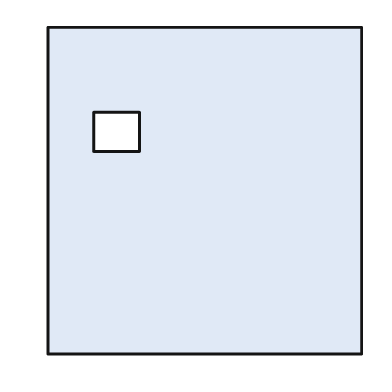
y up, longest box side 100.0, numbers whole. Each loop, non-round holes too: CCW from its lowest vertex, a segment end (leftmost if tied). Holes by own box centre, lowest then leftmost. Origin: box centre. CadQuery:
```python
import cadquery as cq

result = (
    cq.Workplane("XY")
    .moveTo(-48.0, -50.0)
    .lineTo(48.0, -50.0)
    .lineTo(48.0, 50.0)
    .lineTo(-48.0, 50.0)
    .close()
    .moveTo(-34.0, 12.0)
    .lineTo(-20.0, 12.0)
    .lineTo(-20.0, 24.0)
    .lineTo(-34.0, 24.0)
    .close()
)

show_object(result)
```